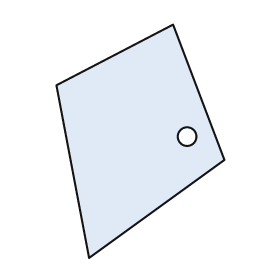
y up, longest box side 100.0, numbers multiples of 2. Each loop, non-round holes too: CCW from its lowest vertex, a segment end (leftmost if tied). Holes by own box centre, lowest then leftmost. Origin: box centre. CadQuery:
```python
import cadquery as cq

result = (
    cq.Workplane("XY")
    .moveTo(-22.0, -50.0)
    .lineTo(36.0, -8.0)
    .lineTo(14.0, 50.0)
    .lineTo(-36.0, 24.0)
    .close()
    .moveTo(20.0, 2.0)
    .circle(4.0)
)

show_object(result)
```